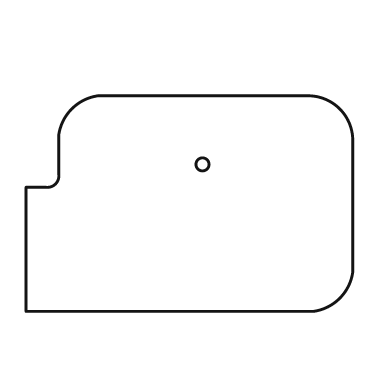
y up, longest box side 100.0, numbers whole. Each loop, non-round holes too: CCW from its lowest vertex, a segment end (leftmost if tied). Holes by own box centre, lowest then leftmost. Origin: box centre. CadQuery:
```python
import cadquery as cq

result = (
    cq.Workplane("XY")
    .moveTo(-50.0, -33.0)
    .lineTo(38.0, -33.0)
    .threePointArc((46.0, -29.0), (50.0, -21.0))
    .lineTo(50.0, 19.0)
    .threePointArc((46.0, 29.0), (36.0, 33.0))
    .lineTo(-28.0, 33.0)
    .threePointArc((-36.0, 29.0), (-40.0, 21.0))
    .lineTo(-40.0, 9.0)
    .threePointArc((-41.0, 6.0), (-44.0, 5.0))
    .lineTo(-50.0, 5.0)
    .close()
    .moveTo(4.0, 12.0)
    .circle(2.0)
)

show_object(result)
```